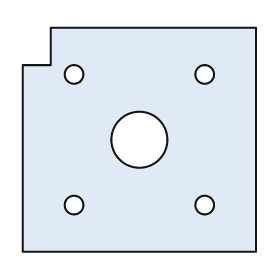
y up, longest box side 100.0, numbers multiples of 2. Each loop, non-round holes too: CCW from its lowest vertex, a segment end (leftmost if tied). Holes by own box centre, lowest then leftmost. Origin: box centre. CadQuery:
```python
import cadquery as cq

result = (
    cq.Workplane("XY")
    .moveTo(-50.0, -48.0)
    .lineTo(50.0, -48.0)
    .lineTo(50.0, 48.0)
    .lineTo(-38.0, 48.0)
    .lineTo(-38.0, 32.0)
    .lineTo(-50.0, 32.0)
    .close()
    .moveTo(-28.0, -28.0)
    .circle(4.0)
    .moveTo(28.0, -28.0)
    .circle(4.0)
    .moveTo(0.0, 0.0)
    .circle(12.0)
    .moveTo(-28.0, 28.0)
    .circle(4.0)
    .moveTo(28.0, 28.0)
    .circle(4.0)
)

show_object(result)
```